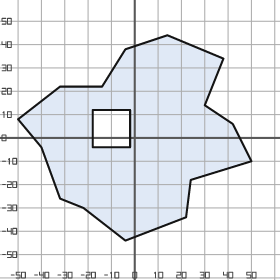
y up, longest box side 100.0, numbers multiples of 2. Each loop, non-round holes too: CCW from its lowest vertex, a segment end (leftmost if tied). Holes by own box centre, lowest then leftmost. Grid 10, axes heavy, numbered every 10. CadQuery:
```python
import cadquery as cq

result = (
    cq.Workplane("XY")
    .moveTo(-4.0, -44.0)
    .lineTo(22.0, -34.0)
    .lineTo(24.0, -18.0)
    .lineTo(50.0, -10.0)
    .lineTo(42.0, 6.0)
    .lineTo(30.0, 14.0)
    .lineTo(38.0, 34.0)
    .lineTo(14.0, 44.0)
    .lineTo(-4.0, 38.0)
    .lineTo(-14.0, 22.0)
    .lineTo(-32.0, 22.0)
    .lineTo(-50.0, 8.0)
    .lineTo(-40.0, -4.0)
    .lineTo(-32.0, -26.0)
    .lineTo(-22.0, -30.0)
    .close()
    .moveTo(-18.0, -4.0)
    .lineTo(-2.0, -4.0)
    .lineTo(-2.0, 12.0)
    .lineTo(-18.0, 12.0)
    .close()
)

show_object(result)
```